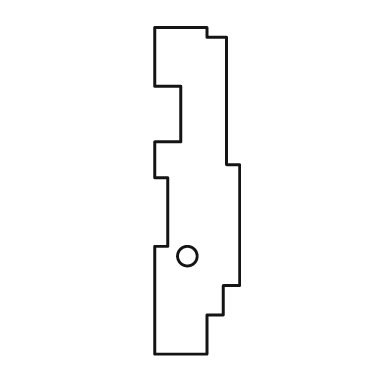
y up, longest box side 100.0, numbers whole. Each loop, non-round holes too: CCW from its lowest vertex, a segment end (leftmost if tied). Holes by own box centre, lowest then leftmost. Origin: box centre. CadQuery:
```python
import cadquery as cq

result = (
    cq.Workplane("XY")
    .moveTo(-13.0, -50.0)
    .lineTo(3.0, -50.0)
    .lineTo(3.0, -38.0)
    .lineTo(8.0, -38.0)
    .lineTo(8.0, -29.0)
    .lineTo(13.0, -29.0)
    .lineTo(13.0, 8.0)
    .lineTo(9.0, 8.0)
    .lineTo(9.0, 47.0)
    .lineTo(3.0, 47.0)
    .lineTo(3.0, 50.0)
    .lineTo(-13.0, 50.0)
    .lineTo(-13.0, 32.0)
    .lineTo(-5.0, 32.0)
    .lineTo(-5.0, 15.0)
    .lineTo(-13.0, 15.0)
    .lineTo(-13.0, 4.0)
    .lineTo(-9.0, 4.0)
    .lineTo(-9.0, -17.0)
    .lineTo(-13.0, -17.0)
    .close()
    .moveTo(-3.0, -20.0)
    .circle(3.0)
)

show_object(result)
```